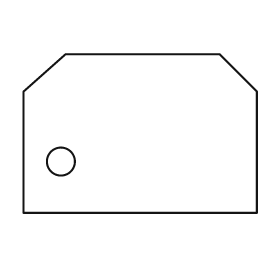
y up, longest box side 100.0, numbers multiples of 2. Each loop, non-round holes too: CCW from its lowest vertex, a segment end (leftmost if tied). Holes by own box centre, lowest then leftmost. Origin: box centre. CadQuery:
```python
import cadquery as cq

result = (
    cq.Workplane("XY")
    .moveTo(-50.0, -34.0)
    .lineTo(50.0, -34.0)
    .lineTo(50.0, 18.0)
    .lineTo(34.0, 34.0)
    .lineTo(-32.0, 34.0)
    .lineTo(-50.0, 18.0)
    .close()
    .moveTo(-34.0, -12.0)
    .circle(6.0)
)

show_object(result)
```